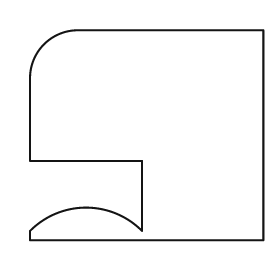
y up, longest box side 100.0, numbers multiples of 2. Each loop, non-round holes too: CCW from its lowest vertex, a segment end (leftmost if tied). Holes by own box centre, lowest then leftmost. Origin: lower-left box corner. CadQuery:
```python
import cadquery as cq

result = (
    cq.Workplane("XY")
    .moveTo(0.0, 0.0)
    .lineTo(100.0, 0.0)
    .lineTo(100.0, 90.0)
    .lineTo(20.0, 90.0)
    .threePointArc((6.0, 84.0), (0.0, 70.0))
    .lineTo(0.0, 34.0)
    .lineTo(48.0, 34.0)
    .lineTo(48.0, 4.0)
    .threePointArc((24.0, 14.0), (0.0, 4.0))
    .close()
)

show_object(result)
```